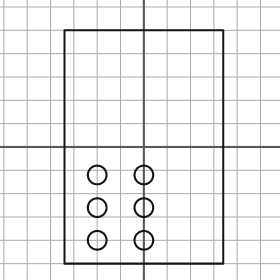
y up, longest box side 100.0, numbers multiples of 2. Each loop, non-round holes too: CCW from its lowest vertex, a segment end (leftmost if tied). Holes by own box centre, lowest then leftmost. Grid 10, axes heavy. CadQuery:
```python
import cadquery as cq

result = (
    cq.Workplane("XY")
    .moveTo(-34.0, -50.0)
    .lineTo(34.0, -50.0)
    .lineTo(34.0, 50.0)
    .lineTo(-34.0, 50.0)
    .close()
    .moveTo(-20.0, -40.0)
    .circle(4.0)
    .moveTo(0.0, -40.0)
    .circle(4.0)
    .moveTo(-20.0, -26.0)
    .circle(4.0)
    .moveTo(0.0, -26.0)
    .circle(4.0)
    .moveTo(-20.0, -12.0)
    .circle(4.0)
    .moveTo(0.0, -12.0)
    .circle(4.0)
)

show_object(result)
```